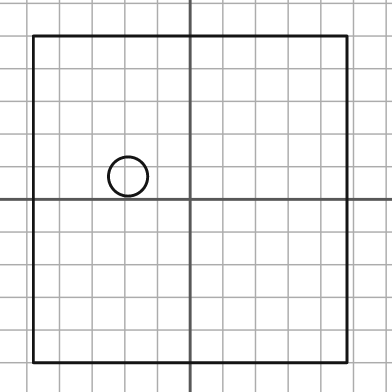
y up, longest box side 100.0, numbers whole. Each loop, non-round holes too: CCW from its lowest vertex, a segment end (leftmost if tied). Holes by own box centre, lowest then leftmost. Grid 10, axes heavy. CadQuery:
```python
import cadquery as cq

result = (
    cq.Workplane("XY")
    .moveTo(-48.0, -50.0)
    .lineTo(48.0, -50.0)
    .lineTo(48.0, 50.0)
    .lineTo(-48.0, 50.0)
    .close()
    .moveTo(-19.0, 7.0)
    .circle(6.0)
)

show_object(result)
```